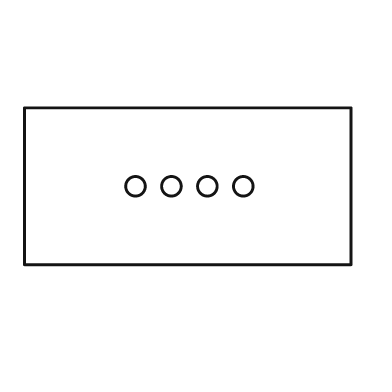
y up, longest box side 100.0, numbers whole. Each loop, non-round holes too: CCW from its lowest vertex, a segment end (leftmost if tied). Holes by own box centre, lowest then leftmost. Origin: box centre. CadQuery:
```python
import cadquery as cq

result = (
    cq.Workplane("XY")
    .moveTo(-50.0, -24.0)
    .lineTo(50.0, -24.0)
    .lineTo(50.0, 24.0)
    .lineTo(-50.0, 24.0)
    .close()
    .moveTo(-16.0, 0.0)
    .circle(3.0)
    .moveTo(-5.0, 0.0)
    .circle(3.0)
    .moveTo(6.0, 0.0)
    .circle(3.0)
    .moveTo(17.0, 0.0)
    .circle(3.0)
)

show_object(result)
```